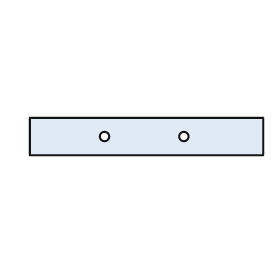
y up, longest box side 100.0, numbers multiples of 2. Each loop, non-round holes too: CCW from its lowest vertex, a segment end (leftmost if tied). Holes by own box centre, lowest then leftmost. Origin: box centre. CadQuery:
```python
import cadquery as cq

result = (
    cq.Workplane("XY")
    .moveTo(-50.0, -8.0)
    .lineTo(50.0, -8.0)
    .lineTo(50.0, 8.0)
    .lineTo(-50.0, 8.0)
    .close()
    .moveTo(-18.0, 0.0)
    .circle(2.0)
    .moveTo(16.0, 0.0)
    .circle(2.0)
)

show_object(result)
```